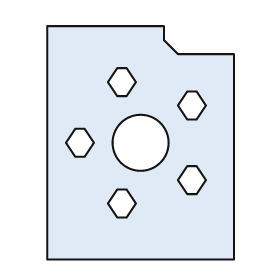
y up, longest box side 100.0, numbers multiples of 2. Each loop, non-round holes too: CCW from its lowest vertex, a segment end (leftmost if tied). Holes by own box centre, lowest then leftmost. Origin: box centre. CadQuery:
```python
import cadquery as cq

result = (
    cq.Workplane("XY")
    .moveTo(-40.0, -50.0)
    .lineTo(40.0, -50.0)
    .lineTo(40.0, 38.0)
    .lineTo(16.0, 38.0)
    .lineTo(10.0, 44.0)
    .lineTo(10.0, 50.0)
    .lineTo(-40.0, 50.0)
    .close()
    .moveTo(-10.0, -32.0)
    .lineTo(-6.0, -32.0)
    .lineTo(-2.0, -26.0)
    .lineTo(-6.0, -20.0)
    .lineTo(-10.0, -20.0)
    .lineTo(-14.0, -26.0)
    .close()
    .moveTo(20.0, -22.0)
    .lineTo(24.0, -22.0)
    .lineTo(28.0, -16.0)
    .lineTo(24.0, -10.0)
    .lineTo(20.0, -10.0)
    .lineTo(16.0, -16.0)
    .close()
    .moveTo(-28.0, -6.0)
    .lineTo(-24.0, -6.0)
    .lineTo(-20.0, 0.0)
    .lineTo(-24.0, 6.0)
    .lineTo(-28.0, 6.0)
    .lineTo(-32.0, 0.0)
    .close()
    .moveTo(0.0, 0.0)
    .circle(12.0)
    .moveTo(20.0, 10.0)
    .lineTo(24.0, 10.0)
    .lineTo(28.0, 16.0)
    .lineTo(24.0, 22.0)
    .lineTo(20.0, 22.0)
    .lineTo(16.0, 16.0)
    .close()
    .moveTo(-10.0, 20.0)
    .lineTo(-6.0, 20.0)
    .lineTo(-2.0, 26.0)
    .lineTo(-6.0, 32.0)
    .lineTo(-10.0, 32.0)
    .lineTo(-14.0, 26.0)
    .close()
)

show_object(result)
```